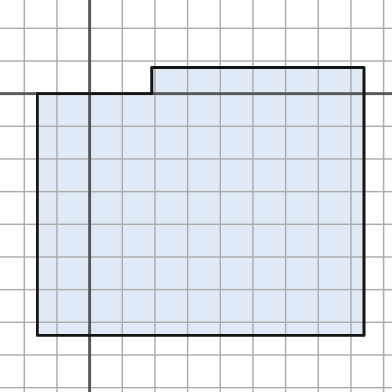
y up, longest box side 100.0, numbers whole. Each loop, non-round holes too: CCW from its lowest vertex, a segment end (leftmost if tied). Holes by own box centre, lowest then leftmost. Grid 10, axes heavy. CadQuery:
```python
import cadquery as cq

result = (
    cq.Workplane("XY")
    .moveTo(-16.0, -74.0)
    .lineTo(84.0, -74.0)
    .lineTo(84.0, 8.0)
    .lineTo(19.0, 8.0)
    .lineTo(19.0, 0.0)
    .lineTo(-16.0, 0.0)
    .close()
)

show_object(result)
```